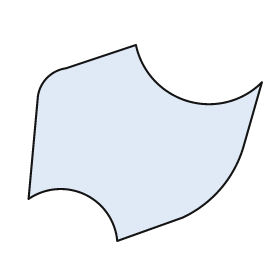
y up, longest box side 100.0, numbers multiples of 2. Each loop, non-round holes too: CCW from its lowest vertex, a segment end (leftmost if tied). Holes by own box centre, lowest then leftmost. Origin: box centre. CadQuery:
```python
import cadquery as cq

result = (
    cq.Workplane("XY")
    .moveTo(-12.0, -42.0)
    .lineTo(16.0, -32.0)
    .threePointArc((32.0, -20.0), (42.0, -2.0))
    .lineTo(50.0, 26.0)
    .threePointArc((18.0, 18.0), (-4.0, 42.0))
    .lineTo(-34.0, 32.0)
    .threePointArc((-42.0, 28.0), (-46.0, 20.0))
    .lineTo(-50.0, -24.0)
    .threePointArc((-26.0, -22.0), (-12.0, -42.0))
    .close()
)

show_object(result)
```